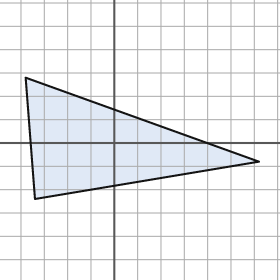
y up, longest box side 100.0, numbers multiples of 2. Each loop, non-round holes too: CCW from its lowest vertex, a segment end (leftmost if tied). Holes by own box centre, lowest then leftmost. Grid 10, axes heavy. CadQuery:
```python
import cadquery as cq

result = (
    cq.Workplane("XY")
    .moveTo(-34.0, -24.0)
    .lineTo(62.0, -8.0)
    .lineTo(-38.0, 28.0)
    .close()
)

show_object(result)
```